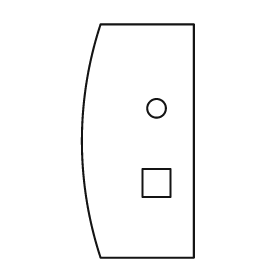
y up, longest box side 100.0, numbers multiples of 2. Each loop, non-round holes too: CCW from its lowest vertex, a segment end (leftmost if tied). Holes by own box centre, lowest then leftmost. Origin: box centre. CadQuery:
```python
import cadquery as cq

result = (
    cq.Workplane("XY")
    .moveTo(-16.0, -50.0)
    .lineTo(24.0, -50.0)
    .lineTo(24.0, 50.0)
    .lineTo(-16.0, 50.0)
    .threePointArc((-24.0, 0.0), (-16.0, -50.0))
    .close()
    .moveTo(2.0, -24.0)
    .lineTo(14.0, -24.0)
    .lineTo(14.0, -12.0)
    .lineTo(2.0, -12.0)
    .close()
    .moveTo(8.0, 14.0)
    .circle(4.0)
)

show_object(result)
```